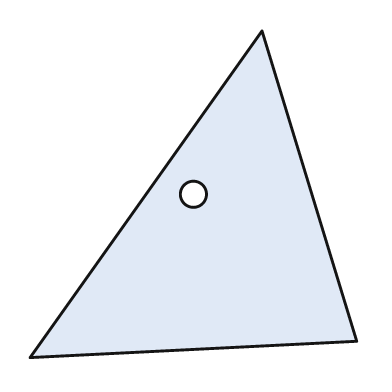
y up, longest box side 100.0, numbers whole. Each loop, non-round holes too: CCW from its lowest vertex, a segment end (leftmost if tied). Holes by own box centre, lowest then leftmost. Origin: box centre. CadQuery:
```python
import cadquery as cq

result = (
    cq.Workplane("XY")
    .moveTo(-50.0, -50.0)
    .lineTo(50.0, -45.0)
    .lineTo(21.0, 50.0)
    .close()
    .moveTo(0.0, 0.0)
    .circle(4.0)
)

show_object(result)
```